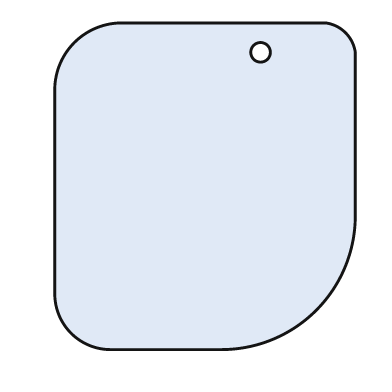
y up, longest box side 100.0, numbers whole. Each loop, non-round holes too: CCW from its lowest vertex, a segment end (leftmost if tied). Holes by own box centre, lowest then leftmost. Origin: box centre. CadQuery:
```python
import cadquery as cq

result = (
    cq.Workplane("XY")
    .moveTo(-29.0, -50.0)
    .lineTo(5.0, -50.0)
    .threePointArc((34.0, -38.0), (46.0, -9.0))
    .lineTo(46.0, 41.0)
    .threePointArc((43.0, 47.0), (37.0, 50.0))
    .lineTo(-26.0, 50.0)
    .threePointArc((-40.0, 44.0), (-46.0, 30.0))
    .lineTo(-46.0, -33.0)
    .threePointArc((-41.0, -45.0), (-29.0, -50.0))
    .close()
    .moveTo(17.0, 41.0)
    .circle(3.0)
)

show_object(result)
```